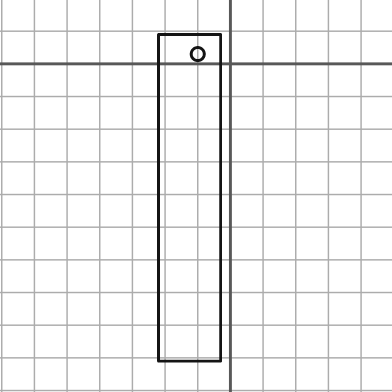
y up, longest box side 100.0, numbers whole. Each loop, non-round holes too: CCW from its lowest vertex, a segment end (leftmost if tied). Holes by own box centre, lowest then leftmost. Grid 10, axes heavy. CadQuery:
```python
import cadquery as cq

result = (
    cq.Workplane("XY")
    .moveTo(-22.0, -91.0)
    .lineTo(-3.0, -91.0)
    .lineTo(-3.0, 9.0)
    .lineTo(-22.0, 9.0)
    .close()
    .moveTo(-10.0, 3.0)
    .circle(2.0)
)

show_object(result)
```